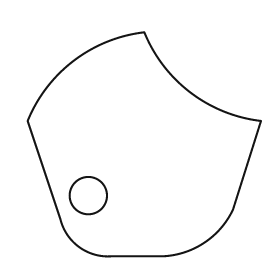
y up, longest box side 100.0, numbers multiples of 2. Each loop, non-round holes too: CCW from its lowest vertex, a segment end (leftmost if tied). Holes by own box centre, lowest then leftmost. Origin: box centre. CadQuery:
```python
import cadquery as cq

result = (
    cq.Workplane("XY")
    .moveTo(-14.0, -48.0)
    .lineTo(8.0, -48.0)
    .threePointArc((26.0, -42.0), (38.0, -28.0))
    .lineTo(50.0, 10.0)
    .threePointArc((20.0, 22.0), (0.0, 48.0))
    .threePointArc((-30.0, 36.0), (-50.0, 10.0))
    .lineTo(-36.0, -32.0)
    .threePointArc((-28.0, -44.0), (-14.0, -48.0))
    .close()
    .moveTo(-24.0, -22.0)
    .circle(8.0)
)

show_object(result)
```